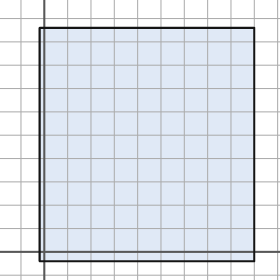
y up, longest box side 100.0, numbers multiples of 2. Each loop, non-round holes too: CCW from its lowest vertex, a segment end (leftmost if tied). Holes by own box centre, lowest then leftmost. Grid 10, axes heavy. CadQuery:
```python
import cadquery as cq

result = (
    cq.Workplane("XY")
    .moveTo(-2.0, -4.0)
    .lineTo(90.0, -4.0)
    .lineTo(90.0, 96.0)
    .lineTo(-2.0, 96.0)
    .close()
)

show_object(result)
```